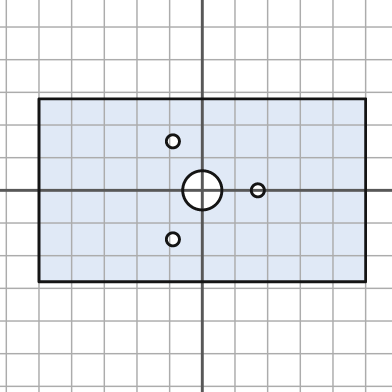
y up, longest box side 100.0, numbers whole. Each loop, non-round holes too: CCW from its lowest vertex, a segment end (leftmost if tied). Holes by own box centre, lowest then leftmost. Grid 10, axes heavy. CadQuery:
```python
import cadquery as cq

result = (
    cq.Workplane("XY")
    .moveTo(-50.0, -28.0)
    .lineTo(50.0, -28.0)
    .lineTo(50.0, 28.0)
    .lineTo(-50.0, 28.0)
    .close()
    .moveTo(-9.0, -15.0)
    .circle(2.0)
    .moveTo(0.0, 0.0)
    .circle(6.0)
    .moveTo(17.0, 0.0)
    .circle(2.0)
    .moveTo(-9.0, 15.0)
    .circle(2.0)
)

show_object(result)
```